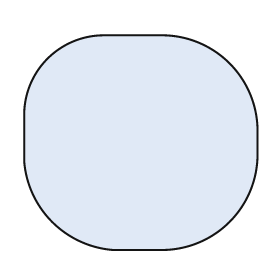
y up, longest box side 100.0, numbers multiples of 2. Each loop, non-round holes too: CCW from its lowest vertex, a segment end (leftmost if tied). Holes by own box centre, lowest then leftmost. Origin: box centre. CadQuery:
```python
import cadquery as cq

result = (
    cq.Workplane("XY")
    .moveTo(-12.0, -46.0)
    .lineTo(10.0, -46.0)
    .threePointArc((38.0, -34.0), (50.0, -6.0))
    .lineTo(50.0, 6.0)
    .threePointArc((38.0, 34.0), (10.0, 46.0))
    .lineTo(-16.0, 46.0)
    .threePointArc((-40.0, 36.0), (-50.0, 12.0))
    .lineTo(-50.0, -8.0)
    .threePointArc((-38.0, -34.0), (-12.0, -46.0))
    .close()
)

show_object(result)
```